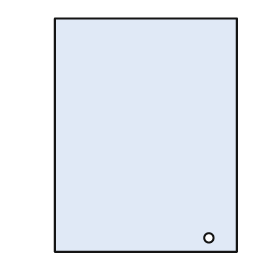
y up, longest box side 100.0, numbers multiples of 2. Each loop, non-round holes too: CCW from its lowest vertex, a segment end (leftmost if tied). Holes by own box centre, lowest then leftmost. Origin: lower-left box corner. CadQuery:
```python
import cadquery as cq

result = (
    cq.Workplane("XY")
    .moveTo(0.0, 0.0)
    .lineTo(78.0, 0.0)
    .lineTo(78.0, 100.0)
    .lineTo(0.0, 100.0)
    .close()
    .moveTo(66.0, 6.0)
    .circle(2.0)
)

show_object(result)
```